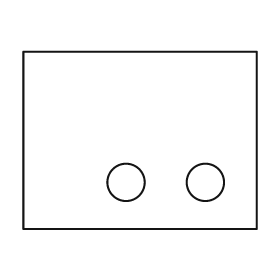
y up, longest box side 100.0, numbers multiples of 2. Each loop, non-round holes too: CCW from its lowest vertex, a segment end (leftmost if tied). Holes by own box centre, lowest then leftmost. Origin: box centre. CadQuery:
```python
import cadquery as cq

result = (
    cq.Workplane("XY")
    .moveTo(-50.0, -38.0)
    .lineTo(50.0, -38.0)
    .lineTo(50.0, 38.0)
    .lineTo(-50.0, 38.0)
    .close()
    .moveTo(-6.0, -18.0)
    .circle(8.0)
    .moveTo(28.0, -18.0)
    .circle(8.0)
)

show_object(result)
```